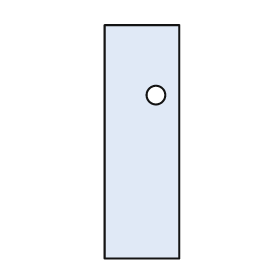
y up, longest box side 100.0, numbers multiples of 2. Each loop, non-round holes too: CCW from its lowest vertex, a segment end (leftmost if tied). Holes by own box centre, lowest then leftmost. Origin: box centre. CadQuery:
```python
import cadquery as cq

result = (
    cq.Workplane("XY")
    .moveTo(-16.0, -50.0)
    .lineTo(16.0, -50.0)
    .lineTo(16.0, 50.0)
    .lineTo(-16.0, 50.0)
    .close()
    .moveTo(6.0, 20.0)
    .circle(4.0)
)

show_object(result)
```